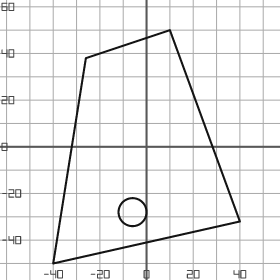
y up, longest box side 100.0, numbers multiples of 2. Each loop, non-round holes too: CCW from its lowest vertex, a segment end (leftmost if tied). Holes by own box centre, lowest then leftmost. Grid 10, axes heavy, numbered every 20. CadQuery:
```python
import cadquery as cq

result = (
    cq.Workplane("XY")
    .moveTo(-40.0, -50.0)
    .lineTo(40.0, -32.0)
    .lineTo(10.0, 50.0)
    .lineTo(-26.0, 38.0)
    .close()
    .moveTo(-6.0, -28.0)
    .circle(6.0)
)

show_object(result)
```